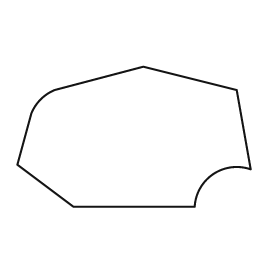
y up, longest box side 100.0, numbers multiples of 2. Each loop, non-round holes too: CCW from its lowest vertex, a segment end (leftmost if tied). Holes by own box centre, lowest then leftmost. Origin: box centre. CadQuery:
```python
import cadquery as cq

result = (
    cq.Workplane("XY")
    .moveTo(-26.0, -30.0)
    .lineTo(26.0, -30.0)
    .threePointArc((34.0, -16.0), (50.0, -14.0))
    .lineTo(44.0, 20.0)
    .lineTo(4.0, 30.0)
    .lineTo(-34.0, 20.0)
    .threePointArc((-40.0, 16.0), (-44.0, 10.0))
    .lineTo(-50.0, -12.0)
    .close()
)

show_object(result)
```